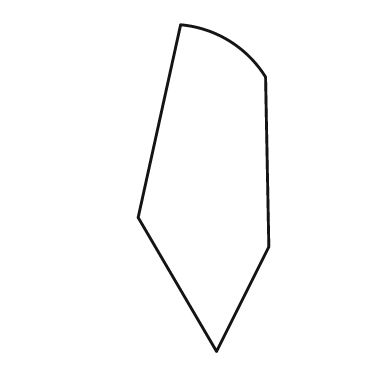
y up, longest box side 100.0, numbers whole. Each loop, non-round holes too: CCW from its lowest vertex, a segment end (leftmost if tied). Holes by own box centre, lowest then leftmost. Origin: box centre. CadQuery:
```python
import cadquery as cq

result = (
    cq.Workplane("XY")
    .moveTo(4.0, -50.0)
    .lineTo(20.0, -18.0)
    .lineTo(19.0, 34.0)
    .threePointArc((8.0, 45.0), (-7.0, 50.0))
    .lineTo(-20.0, -9.0)
    .close()
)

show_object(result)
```